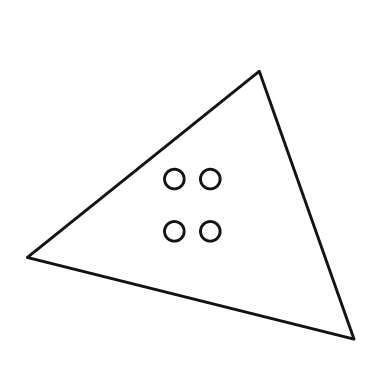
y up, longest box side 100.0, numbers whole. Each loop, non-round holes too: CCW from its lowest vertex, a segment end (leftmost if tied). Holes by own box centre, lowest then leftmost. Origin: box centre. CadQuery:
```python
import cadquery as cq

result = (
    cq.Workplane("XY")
    .moveTo(50.0, -41.0)
    .lineTo(21.0, 41.0)
    .lineTo(-50.0, -16.0)
    .close()
    .moveTo(-5.0, -8.0)
    .circle(3.0)
    .moveTo(6.0, -8.0)
    .circle(3.0)
    .moveTo(-5.0, 8.0)
    .circle(3.0)
    .moveTo(6.0, 8.0)
    .circle(3.0)
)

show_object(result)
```